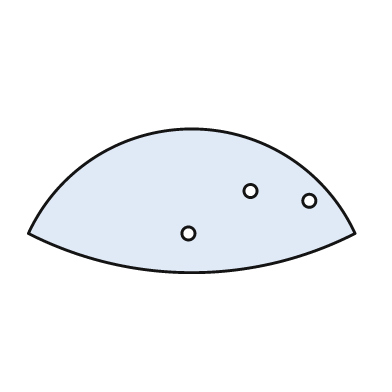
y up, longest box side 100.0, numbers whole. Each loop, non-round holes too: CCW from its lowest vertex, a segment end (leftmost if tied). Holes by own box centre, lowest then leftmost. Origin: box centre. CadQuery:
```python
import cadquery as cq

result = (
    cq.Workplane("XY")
    .moveTo(-50.0, -10.0)
    .threePointArc((0.0, -22.0), (50.0, -10.0))
    .threePointArc((0.0, 22.0), (-50.0, -10.0))
    .close()
    .moveTo(-1.0, -10.0)
    .circle(2.0)
    .moveTo(36.0, 0.0)
    .circle(2.0)
    .moveTo(18.0, 3.0)
    .circle(2.0)
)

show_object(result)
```